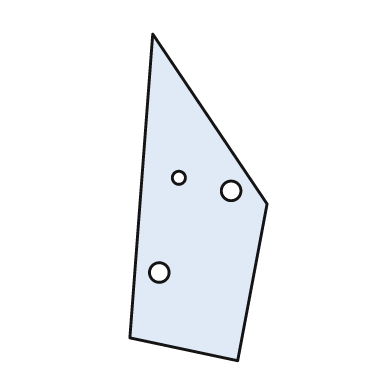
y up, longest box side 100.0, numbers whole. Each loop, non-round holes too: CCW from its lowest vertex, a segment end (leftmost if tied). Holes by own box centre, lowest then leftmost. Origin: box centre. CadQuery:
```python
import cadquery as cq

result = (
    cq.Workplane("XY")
    .moveTo(12.0, -50.0)
    .lineTo(21.0, -2.0)
    .lineTo(-14.0, 50.0)
    .lineTo(-21.0, -43.0)
    .close()
    .moveTo(-12.0, -23.0)
    .circle(3.0)
    .moveTo(10.0, 2.0)
    .circle(3.0)
    .moveTo(-6.0, 6.0)
    .circle(2.0)
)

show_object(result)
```